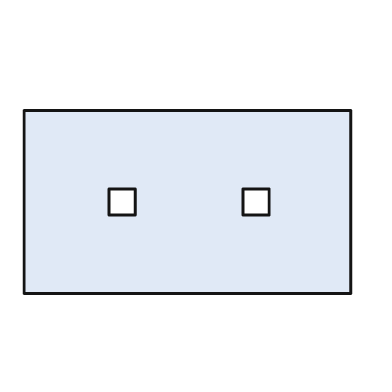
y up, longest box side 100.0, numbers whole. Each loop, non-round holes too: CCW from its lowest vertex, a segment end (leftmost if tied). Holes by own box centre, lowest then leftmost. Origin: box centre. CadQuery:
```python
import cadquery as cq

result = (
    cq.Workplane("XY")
    .moveTo(-50.0, -28.0)
    .lineTo(50.0, -28.0)
    .lineTo(50.0, 28.0)
    .lineTo(-50.0, 28.0)
    .close()
    .moveTo(-24.0, -4.0)
    .lineTo(-16.0, -4.0)
    .lineTo(-16.0, 4.0)
    .lineTo(-24.0, 4.0)
    .close()
    .moveTo(17.0, -4.0)
    .lineTo(25.0, -4.0)
    .lineTo(25.0, 4.0)
    .lineTo(17.0, 4.0)
    .close()
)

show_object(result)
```